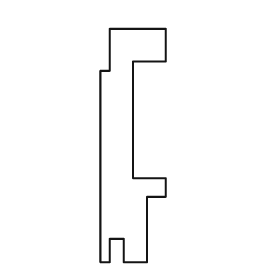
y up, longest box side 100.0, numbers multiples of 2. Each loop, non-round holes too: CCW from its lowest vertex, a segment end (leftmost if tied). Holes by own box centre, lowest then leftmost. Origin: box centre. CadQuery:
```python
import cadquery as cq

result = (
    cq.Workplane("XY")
    .moveTo(-14.0, -50.0)
    .lineTo(-10.0, -50.0)
    .lineTo(-10.0, -40.0)
    .lineTo(-4.0, -40.0)
    .lineTo(-4.0, -50.0)
    .lineTo(6.0, -50.0)
    .lineTo(6.0, -22.0)
    .lineTo(14.0, -22.0)
    .lineTo(14.0, -14.0)
    .lineTo(0.0, -14.0)
    .lineTo(0.0, 36.0)
    .lineTo(14.0, 36.0)
    .lineTo(14.0, 50.0)
    .lineTo(-10.0, 50.0)
    .lineTo(-10.0, 32.0)
    .lineTo(-14.0, 32.0)
    .close()
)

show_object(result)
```